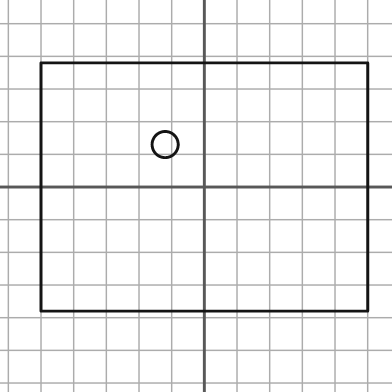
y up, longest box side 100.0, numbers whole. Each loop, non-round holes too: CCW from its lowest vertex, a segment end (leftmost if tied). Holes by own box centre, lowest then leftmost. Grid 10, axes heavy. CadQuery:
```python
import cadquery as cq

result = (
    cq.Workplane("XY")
    .moveTo(-50.0, -38.0)
    .lineTo(50.0, -38.0)
    .lineTo(50.0, 38.0)
    .lineTo(-50.0, 38.0)
    .close()
    .moveTo(-12.0, 13.0)
    .circle(4.0)
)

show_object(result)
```